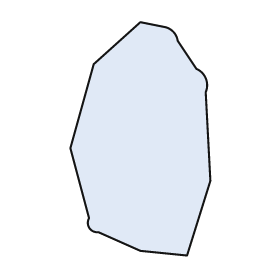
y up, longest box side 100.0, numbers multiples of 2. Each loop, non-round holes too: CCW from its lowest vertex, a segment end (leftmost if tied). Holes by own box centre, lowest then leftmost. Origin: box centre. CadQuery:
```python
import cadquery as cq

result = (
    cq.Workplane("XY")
    .moveTo(20.0, -50.0)
    .lineTo(30.0, -18.0)
    .lineTo(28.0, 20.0)
    .threePointArc((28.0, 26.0), (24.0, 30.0))
    .lineTo(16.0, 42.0)
    .threePointArc((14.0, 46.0), (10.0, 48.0))
    .lineTo(0.0, 50.0)
    .lineTo(-20.0, 32.0)
    .lineTo(-30.0, -4.0)
    .lineTo(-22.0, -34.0)
    .threePointArc((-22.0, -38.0), (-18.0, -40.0))
    .lineTo(0.0, -48.0)
    .close()
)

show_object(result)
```